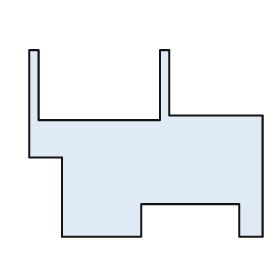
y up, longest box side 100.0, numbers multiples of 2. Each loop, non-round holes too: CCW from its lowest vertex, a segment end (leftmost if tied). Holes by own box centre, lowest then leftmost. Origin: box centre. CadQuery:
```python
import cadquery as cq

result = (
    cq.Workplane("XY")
    .moveTo(-36.0, -40.0)
    .lineTo(-2.0, -40.0)
    .lineTo(-2.0, -26.0)
    .lineTo(40.0, -26.0)
    .lineTo(40.0, -40.0)
    .lineTo(50.0, -40.0)
    .lineTo(50.0, 12.0)
    .lineTo(10.0, 12.0)
    .lineTo(10.0, 40.0)
    .lineTo(6.0, 40.0)
    .lineTo(6.0, 10.0)
    .lineTo(-46.0, 10.0)
    .lineTo(-46.0, 40.0)
    .lineTo(-50.0, 40.0)
    .lineTo(-50.0, -6.0)
    .lineTo(-36.0, -6.0)
    .close()
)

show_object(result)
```